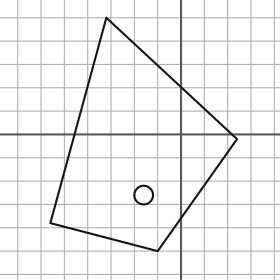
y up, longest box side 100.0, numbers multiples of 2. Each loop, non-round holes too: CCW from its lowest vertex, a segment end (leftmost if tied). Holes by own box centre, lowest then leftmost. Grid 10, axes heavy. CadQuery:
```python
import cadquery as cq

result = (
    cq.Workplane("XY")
    .moveTo(-10.0, -50.0)
    .lineTo(24.0, -2.0)
    .lineTo(-32.0, 50.0)
    .lineTo(-56.0, -38.0)
    .close()
    .moveTo(-16.0, -26.0)
    .circle(4.0)
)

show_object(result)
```